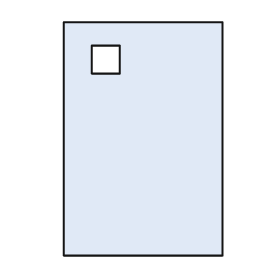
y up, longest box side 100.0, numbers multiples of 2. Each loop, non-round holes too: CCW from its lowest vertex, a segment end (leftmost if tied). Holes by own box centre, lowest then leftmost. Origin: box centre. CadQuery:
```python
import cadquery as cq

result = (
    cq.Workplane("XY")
    .moveTo(-34.0, -50.0)
    .lineTo(34.0, -50.0)
    .lineTo(34.0, 50.0)
    .lineTo(-34.0, 50.0)
    .close()
    .moveTo(-22.0, 28.0)
    .lineTo(-10.0, 28.0)
    .lineTo(-10.0, 40.0)
    .lineTo(-22.0, 40.0)
    .close()
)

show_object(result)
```